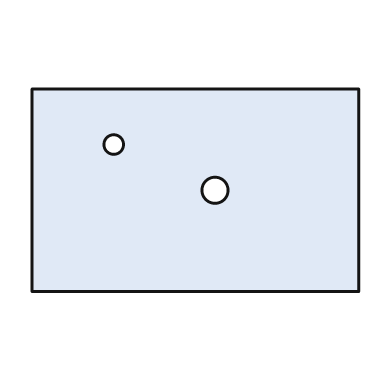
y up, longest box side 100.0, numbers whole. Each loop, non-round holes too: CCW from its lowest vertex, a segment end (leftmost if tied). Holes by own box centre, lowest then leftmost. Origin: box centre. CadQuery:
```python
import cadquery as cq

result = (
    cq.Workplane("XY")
    .moveTo(-50.0, -31.0)
    .lineTo(50.0, -31.0)
    .lineTo(50.0, 31.0)
    .lineTo(-50.0, 31.0)
    .close()
    .moveTo(6.0, 0.0)
    .circle(4.0)
    .moveTo(-25.0, 14.0)
    .circle(3.0)
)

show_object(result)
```